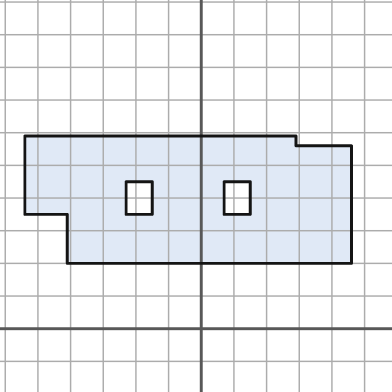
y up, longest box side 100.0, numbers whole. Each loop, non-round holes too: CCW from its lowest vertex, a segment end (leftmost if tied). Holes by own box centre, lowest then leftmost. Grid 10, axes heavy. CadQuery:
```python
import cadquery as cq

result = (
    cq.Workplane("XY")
    .moveTo(-41.0, 20.0)
    .lineTo(46.0, 20.0)
    .lineTo(46.0, 56.0)
    .lineTo(29.0, 56.0)
    .lineTo(29.0, 59.0)
    .lineTo(-54.0, 59.0)
    .lineTo(-54.0, 35.0)
    .lineTo(-41.0, 35.0)
    .close()
    .moveTo(-23.0, 35.0)
    .lineTo(-15.0, 35.0)
    .lineTo(-15.0, 45.0)
    .lineTo(-23.0, 45.0)
    .close()
    .moveTo(7.0, 35.0)
    .lineTo(15.0, 35.0)
    .lineTo(15.0, 45.0)
    .lineTo(7.0, 45.0)
    .close()
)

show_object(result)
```